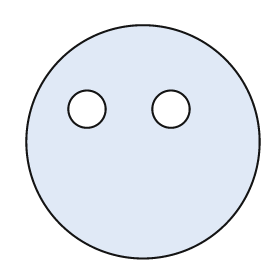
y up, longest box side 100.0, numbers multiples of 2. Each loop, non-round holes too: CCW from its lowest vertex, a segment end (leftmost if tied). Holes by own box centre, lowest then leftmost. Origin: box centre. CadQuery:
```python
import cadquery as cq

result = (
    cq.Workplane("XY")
    .moveTo(0.0, 0.0)
    .circle(50.0)
    .moveTo(-24.0, 14.0)
    .circle(8.0)
    .moveTo(12.0, 14.0)
    .circle(8.0)
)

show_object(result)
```